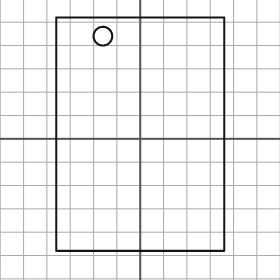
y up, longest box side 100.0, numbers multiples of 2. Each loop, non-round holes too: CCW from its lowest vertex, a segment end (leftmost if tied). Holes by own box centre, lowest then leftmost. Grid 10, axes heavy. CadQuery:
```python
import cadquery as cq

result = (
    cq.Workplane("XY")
    .moveTo(-36.0, -48.0)
    .lineTo(36.0, -48.0)
    .lineTo(36.0, 52.0)
    .lineTo(-36.0, 52.0)
    .close()
    .moveTo(-16.0, 44.0)
    .circle(4.0)
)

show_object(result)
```